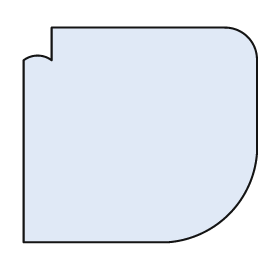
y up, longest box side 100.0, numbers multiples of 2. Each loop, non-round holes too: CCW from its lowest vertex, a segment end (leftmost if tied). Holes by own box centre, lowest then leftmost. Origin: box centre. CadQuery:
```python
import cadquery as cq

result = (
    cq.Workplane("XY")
    .moveTo(-50.0, -46.0)
    .lineTo(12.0, -46.0)
    .threePointArc((38.0, -34.0), (50.0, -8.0))
    .lineTo(50.0, 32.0)
    .threePointArc((46.0, 42.0), (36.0, 46.0))
    .lineTo(-38.0, 46.0)
    .lineTo(-38.0, 32.0)
    .threePointArc((-44.0, 34.0), (-50.0, 32.0))
    .close()
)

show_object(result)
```